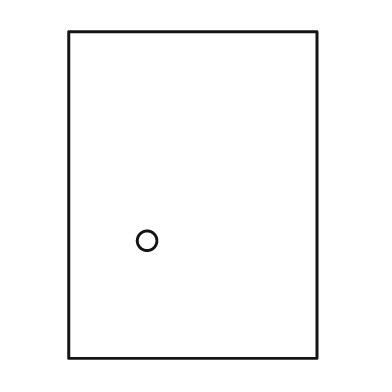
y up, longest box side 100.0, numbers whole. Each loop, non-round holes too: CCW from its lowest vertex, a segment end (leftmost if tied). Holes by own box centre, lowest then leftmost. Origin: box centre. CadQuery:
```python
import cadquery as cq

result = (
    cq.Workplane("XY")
    .moveTo(-38.0, -50.0)
    .lineTo(38.0, -50.0)
    .lineTo(38.0, 50.0)
    .lineTo(-38.0, 50.0)
    .close()
    .moveTo(-14.0, -14.0)
    .circle(3.0)
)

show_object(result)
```